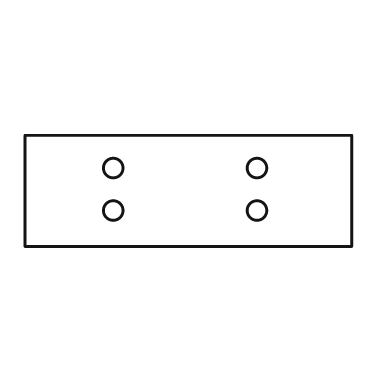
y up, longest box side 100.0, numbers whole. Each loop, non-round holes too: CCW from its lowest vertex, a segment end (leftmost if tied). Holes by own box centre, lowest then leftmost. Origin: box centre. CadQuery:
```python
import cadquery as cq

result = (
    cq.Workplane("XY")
    .moveTo(-50.0, -17.0)
    .lineTo(50.0, -17.0)
    .lineTo(50.0, 17.0)
    .lineTo(-50.0, 17.0)
    .close()
    .moveTo(-23.0, -6.0)
    .circle(3.0)
    .moveTo(21.0, -6.0)
    .circle(3.0)
    .moveTo(-23.0, 7.0)
    .circle(3.0)
    .moveTo(21.0, 7.0)
    .circle(3.0)
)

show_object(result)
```